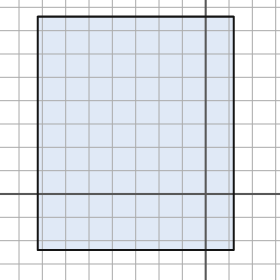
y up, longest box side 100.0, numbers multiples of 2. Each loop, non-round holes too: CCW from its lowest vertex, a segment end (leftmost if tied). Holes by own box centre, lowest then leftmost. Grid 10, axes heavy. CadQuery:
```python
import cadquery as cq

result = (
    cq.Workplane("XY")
    .moveTo(-72.0, -24.0)
    .lineTo(12.0, -24.0)
    .lineTo(12.0, 76.0)
    .lineTo(-72.0, 76.0)
    .close()
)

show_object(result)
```